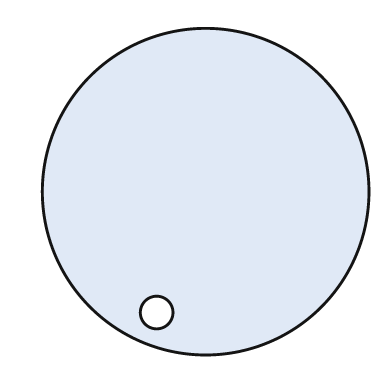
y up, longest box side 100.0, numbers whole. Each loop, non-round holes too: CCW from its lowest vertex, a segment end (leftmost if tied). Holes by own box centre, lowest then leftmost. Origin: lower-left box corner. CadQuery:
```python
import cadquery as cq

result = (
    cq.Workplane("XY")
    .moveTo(50.0, 50.0)
    .circle(50.0)
    .moveTo(35.0, 13.0)
    .circle(5.0)
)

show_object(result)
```